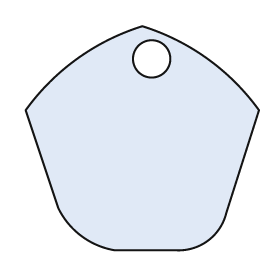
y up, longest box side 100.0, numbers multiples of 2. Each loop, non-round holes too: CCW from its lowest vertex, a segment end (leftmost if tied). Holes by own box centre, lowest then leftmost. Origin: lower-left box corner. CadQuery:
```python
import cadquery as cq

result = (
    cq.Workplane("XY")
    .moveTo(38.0, 0.0)
    .lineTo(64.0, 0.0)
    .threePointArc((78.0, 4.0), (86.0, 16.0))
    .lineTo(100.0, 60.0)
    .threePointArc((78.0, 82.0), (50.0, 96.0))
    .threePointArc((22.0, 82.0), (0.0, 60.0))
    .lineTo(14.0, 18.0)
    .threePointArc((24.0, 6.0), (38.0, 0.0))
    .close()
    .moveTo(54.0, 82.0)
    .circle(8.0)
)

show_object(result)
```